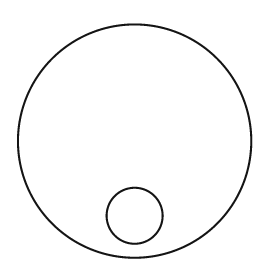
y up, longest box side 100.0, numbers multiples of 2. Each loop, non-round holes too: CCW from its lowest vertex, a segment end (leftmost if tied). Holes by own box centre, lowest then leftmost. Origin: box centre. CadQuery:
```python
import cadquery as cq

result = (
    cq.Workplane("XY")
    .moveTo(0.0, 0.0)
    .circle(50.0)
    .moveTo(0.0, -32.0)
    .circle(12.0)
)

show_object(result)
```